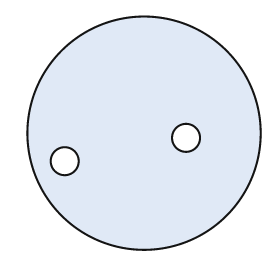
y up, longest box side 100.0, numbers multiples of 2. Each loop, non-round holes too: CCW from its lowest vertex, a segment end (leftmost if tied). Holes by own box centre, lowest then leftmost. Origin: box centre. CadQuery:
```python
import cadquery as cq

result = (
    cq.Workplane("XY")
    .moveTo(0.0, 0.0)
    .circle(50.0)
    .moveTo(-34.0, -12.0)
    .circle(6.0)
    .moveTo(18.0, -2.0)
    .circle(6.0)
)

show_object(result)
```